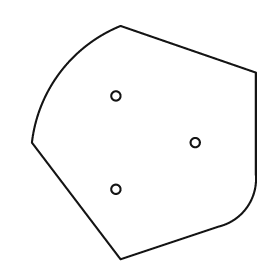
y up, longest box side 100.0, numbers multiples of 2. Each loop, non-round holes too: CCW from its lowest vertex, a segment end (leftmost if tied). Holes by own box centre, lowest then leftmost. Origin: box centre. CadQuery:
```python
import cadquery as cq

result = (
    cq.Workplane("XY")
    .moveTo(-10.0, -50.0)
    .lineTo(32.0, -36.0)
    .threePointArc((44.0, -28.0), (48.0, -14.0))
    .lineTo(48.0, 30.0)
    .lineTo(-10.0, 50.0)
    .threePointArc((-36.0, 30.0), (-48.0, 0.0))
    .close()
    .moveTo(-12.0, -20.0)
    .circle(2.0)
    .moveTo(22.0, 0.0)
    .circle(2.0)
    .moveTo(-12.0, 20.0)
    .circle(2.0)
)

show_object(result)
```